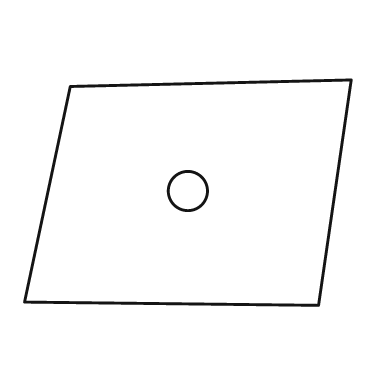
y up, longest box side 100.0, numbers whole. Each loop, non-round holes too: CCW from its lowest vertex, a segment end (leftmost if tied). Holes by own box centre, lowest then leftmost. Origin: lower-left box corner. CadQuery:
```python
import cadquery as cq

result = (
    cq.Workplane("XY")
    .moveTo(90.0, 0.0)
    .lineTo(100.0, 69.0)
    .lineTo(14.0, 67.0)
    .lineTo(0.0, 1.0)
    .close()
    .moveTo(50.0, 35.0)
    .circle(6.0)
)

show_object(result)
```